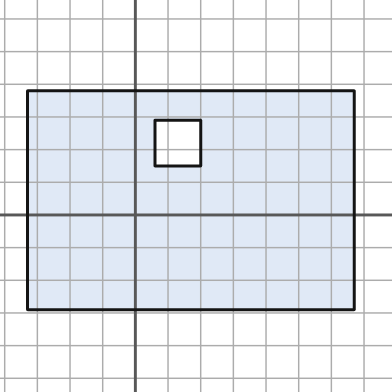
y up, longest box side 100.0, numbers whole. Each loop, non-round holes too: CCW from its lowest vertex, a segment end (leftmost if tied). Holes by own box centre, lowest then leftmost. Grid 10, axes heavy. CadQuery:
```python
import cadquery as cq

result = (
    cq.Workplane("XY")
    .moveTo(-33.0, -29.0)
    .lineTo(67.0, -29.0)
    .lineTo(67.0, 38.0)
    .lineTo(-33.0, 38.0)
    .close()
    .moveTo(6.0, 15.0)
    .lineTo(20.0, 15.0)
    .lineTo(20.0, 29.0)
    .lineTo(6.0, 29.0)
    .close()
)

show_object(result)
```